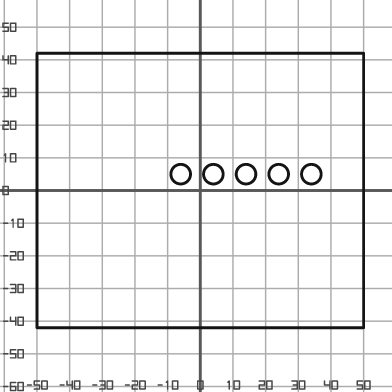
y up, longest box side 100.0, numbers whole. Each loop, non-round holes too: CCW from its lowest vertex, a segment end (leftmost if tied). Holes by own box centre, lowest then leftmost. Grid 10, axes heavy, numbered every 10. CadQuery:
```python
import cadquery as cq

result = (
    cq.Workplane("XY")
    .moveTo(-50.0, -42.0)
    .lineTo(50.0, -42.0)
    .lineTo(50.0, 42.0)
    .lineTo(-50.0, 42.0)
    .close()
    .moveTo(-6.0, 5.0)
    .circle(3.0)
    .moveTo(4.0, 5.0)
    .circle(3.0)
    .moveTo(14.0, 5.0)
    .circle(3.0)
    .moveTo(24.0, 5.0)
    .circle(3.0)
    .moveTo(34.0, 5.0)
    .circle(3.0)
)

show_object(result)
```